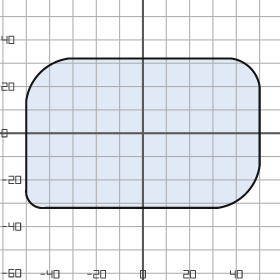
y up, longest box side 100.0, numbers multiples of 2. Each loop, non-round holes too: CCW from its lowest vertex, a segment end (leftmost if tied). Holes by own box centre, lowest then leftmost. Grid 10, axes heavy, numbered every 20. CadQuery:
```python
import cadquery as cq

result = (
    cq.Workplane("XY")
    .moveTo(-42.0, -32.0)
    .lineTo(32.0, -32.0)
    .threePointArc((44.0, -26.0), (50.0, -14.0))
    .lineTo(50.0, 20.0)
    .threePointArc((46.0, 28.0), (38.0, 32.0))
    .lineTo(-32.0, 32.0)
    .threePointArc((-44.0, 26.0), (-50.0, 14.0))
    .lineTo(-50.0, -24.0)
    .threePointArc((-48.0, -30.0), (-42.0, -32.0))
    .close()
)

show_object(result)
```